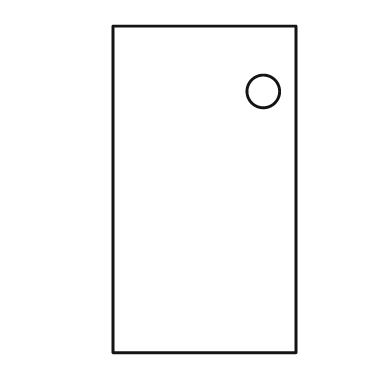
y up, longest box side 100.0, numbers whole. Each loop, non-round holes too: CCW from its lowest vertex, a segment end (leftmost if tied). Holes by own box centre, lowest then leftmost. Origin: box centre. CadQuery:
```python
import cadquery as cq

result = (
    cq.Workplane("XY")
    .moveTo(-28.0, -50.0)
    .lineTo(28.0, -50.0)
    .lineTo(28.0, 50.0)
    .lineTo(-28.0, 50.0)
    .close()
    .moveTo(18.0, 30.0)
    .circle(5.0)
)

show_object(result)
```